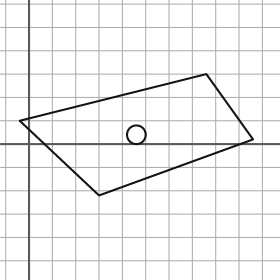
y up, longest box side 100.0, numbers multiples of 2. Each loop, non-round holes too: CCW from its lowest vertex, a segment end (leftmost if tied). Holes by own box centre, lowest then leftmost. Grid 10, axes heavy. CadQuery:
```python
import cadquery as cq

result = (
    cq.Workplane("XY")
    .moveTo(30.0, -22.0)
    .lineTo(96.0, 2.0)
    .lineTo(76.0, 30.0)
    .lineTo(-4.0, 10.0)
    .close()
    .moveTo(46.0, 4.0)
    .circle(4.0)
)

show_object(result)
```